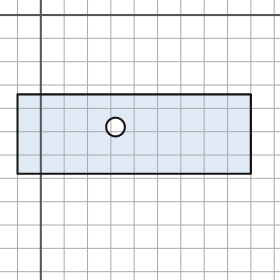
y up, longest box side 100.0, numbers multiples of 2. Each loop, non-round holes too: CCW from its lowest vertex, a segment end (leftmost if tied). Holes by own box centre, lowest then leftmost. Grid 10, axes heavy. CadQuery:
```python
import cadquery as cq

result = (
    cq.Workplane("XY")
    .moveTo(-10.0, -68.0)
    .lineTo(90.0, -68.0)
    .lineTo(90.0, -34.0)
    .lineTo(-10.0, -34.0)
    .close()
    .moveTo(32.0, -48.0)
    .circle(4.0)
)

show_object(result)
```